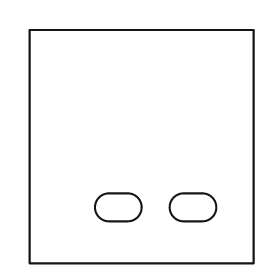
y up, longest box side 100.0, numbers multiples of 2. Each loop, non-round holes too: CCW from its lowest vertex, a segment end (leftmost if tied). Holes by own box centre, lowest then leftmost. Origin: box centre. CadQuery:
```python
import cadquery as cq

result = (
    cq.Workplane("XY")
    .moveTo(-48.0, -50.0)
    .lineTo(48.0, -50.0)
    .lineTo(48.0, 50.0)
    .lineTo(-48.0, 50.0)
    .close()
    .moveTo(-14.0, -32.0)
    .lineTo(-6.0, -32.0)
    .threePointArc((0.0, -26.0), (-6.0, -20.0))
    .lineTo(-14.0, -20.0)
    .threePointArc((-20.0, -26.0), (-14.0, -32.0))
    .close()
    .moveTo(18.0, -32.0)
    .lineTo(26.0, -32.0)
    .threePointArc((32.0, -26.0), (26.0, -20.0))
    .lineTo(18.0, -20.0)
    .threePointArc((12.0, -26.0), (18.0, -32.0))
    .close()
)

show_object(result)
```